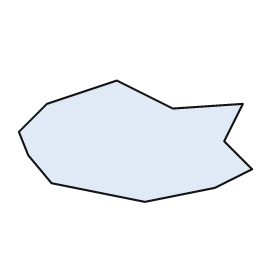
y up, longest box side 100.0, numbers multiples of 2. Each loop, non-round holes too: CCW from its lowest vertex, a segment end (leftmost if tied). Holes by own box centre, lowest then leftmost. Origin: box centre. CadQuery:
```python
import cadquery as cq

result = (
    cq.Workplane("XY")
    .moveTo(4.0, -26.0)
    .lineTo(34.0, -20.0)
    .lineTo(50.0, -12.0)
    .lineTo(38.0, 0.0)
    .lineTo(46.0, 16.0)
    .lineTo(16.0, 14.0)
    .lineTo(-8.0, 26.0)
    .lineTo(-38.0, 16.0)
    .lineTo(-50.0, 4.0)
    .lineTo(-46.0, -6.0)
    .lineTo(-36.0, -18.0)
    .close()
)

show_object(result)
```